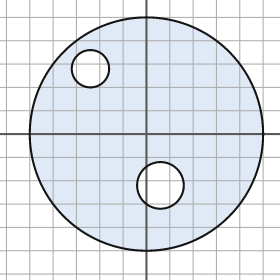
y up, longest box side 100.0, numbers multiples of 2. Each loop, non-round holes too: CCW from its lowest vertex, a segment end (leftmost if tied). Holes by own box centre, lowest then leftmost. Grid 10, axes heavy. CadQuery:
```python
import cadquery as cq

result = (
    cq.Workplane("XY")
    .moveTo(0.0, 0.0)
    .circle(50.0)
    .moveTo(6.0, -22.0)
    .circle(10.0)
    .moveTo(-24.0, 28.0)
    .circle(8.0)
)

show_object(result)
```